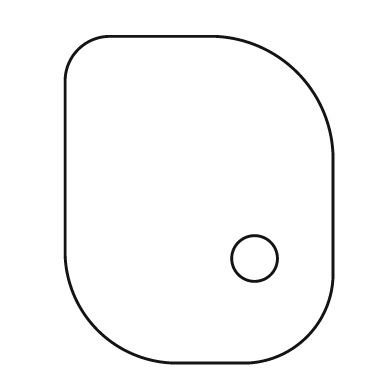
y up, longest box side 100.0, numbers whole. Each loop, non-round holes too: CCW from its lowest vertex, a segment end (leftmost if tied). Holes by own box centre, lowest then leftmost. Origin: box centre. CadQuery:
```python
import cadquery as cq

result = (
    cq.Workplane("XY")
    .moveTo(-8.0, -50.0)
    .lineTo(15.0, -50.0)
    .threePointArc((33.0, -42.0), (41.0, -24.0))
    .lineTo(41.0, 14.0)
    .threePointArc((30.0, 39.0), (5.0, 50.0))
    .lineTo(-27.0, 50.0)
    .threePointArc((-37.0, 46.0), (-41.0, 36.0))
    .lineTo(-41.0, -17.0)
    .threePointArc((-31.0, -40.0), (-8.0, -50.0))
    .close()
    .moveTo(17.0, -18.0)
    .circle(7.0)
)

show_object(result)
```